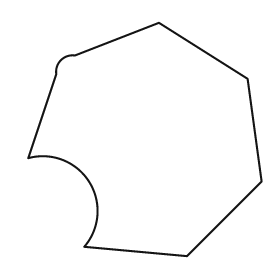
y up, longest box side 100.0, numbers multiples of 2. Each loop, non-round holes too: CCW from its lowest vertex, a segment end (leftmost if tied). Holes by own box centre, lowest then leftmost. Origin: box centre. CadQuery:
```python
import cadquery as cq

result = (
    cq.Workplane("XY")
    .moveTo(18.0, -50.0)
    .lineTo(50.0, -18.0)
    .lineTo(44.0, 26.0)
    .lineTo(6.0, 50.0)
    .lineTo(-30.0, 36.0)
    .threePointArc((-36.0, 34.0), (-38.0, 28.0))
    .lineTo(-50.0, -8.0)
    .threePointArc((-24.0, -18.0), (-26.0, -46.0))
    .close()
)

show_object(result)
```